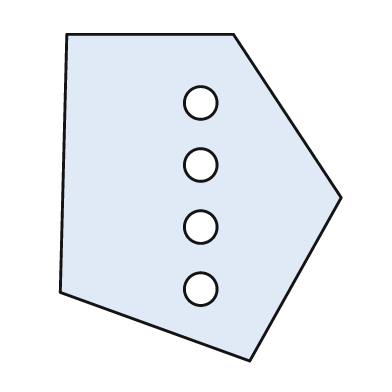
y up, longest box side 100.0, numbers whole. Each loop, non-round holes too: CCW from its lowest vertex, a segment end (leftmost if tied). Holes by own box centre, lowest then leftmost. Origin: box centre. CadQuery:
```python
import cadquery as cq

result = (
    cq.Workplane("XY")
    .moveTo(15.0, -50.0)
    .lineTo(43.0, 0.0)
    .lineTo(10.0, 50.0)
    .lineTo(-41.0, 50.0)
    .lineTo(-43.0, -29.0)
    .close()
    .moveTo(0.0, -28.0)
    .circle(5.0)
    .moveTo(0.0, -9.0)
    .circle(5.0)
    .moveTo(0.0, 10.0)
    .circle(5.0)
    .moveTo(0.0, 29.0)
    .circle(5.0)
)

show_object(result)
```